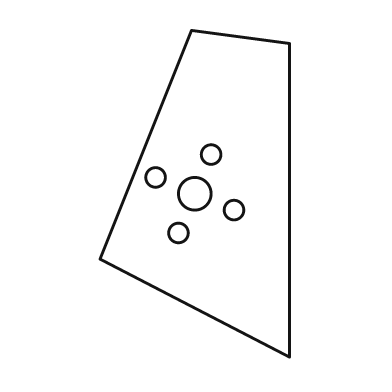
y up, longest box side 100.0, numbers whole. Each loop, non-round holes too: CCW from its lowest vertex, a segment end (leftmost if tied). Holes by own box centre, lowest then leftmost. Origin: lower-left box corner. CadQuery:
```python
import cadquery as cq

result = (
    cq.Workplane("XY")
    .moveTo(58.0, 0.0)
    .lineTo(58.0, 96.0)
    .lineTo(28.0, 100.0)
    .lineTo(0.0, 30.0)
    .close()
    .moveTo(24.0, 38.0)
    .circle(3.0)
    .moveTo(41.0, 45.0)
    .circle(3.0)
    .moveTo(29.0, 50.0)
    .circle(5.0)
    .moveTo(17.0, 55.0)
    .circle(3.0)
    .moveTo(34.0, 62.0)
    .circle(3.0)
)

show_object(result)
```